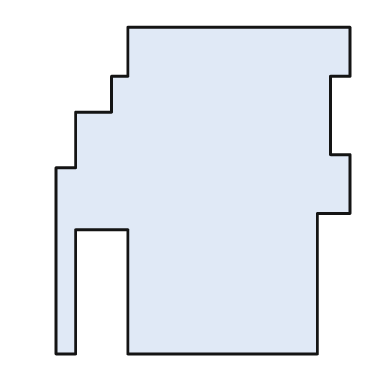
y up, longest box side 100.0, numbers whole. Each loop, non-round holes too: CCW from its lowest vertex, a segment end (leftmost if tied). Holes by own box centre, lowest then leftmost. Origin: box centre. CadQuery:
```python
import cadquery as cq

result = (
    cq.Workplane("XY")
    .moveTo(-45.0, -50.0)
    .lineTo(-39.0, -50.0)
    .lineTo(-39.0, -12.0)
    .lineTo(-23.0, -12.0)
    .lineTo(-23.0, -50.0)
    .lineTo(35.0, -50.0)
    .lineTo(35.0, -7.0)
    .lineTo(45.0, -7.0)
    .lineTo(45.0, 11.0)
    .lineTo(39.0, 11.0)
    .lineTo(39.0, 35.0)
    .lineTo(45.0, 35.0)
    .lineTo(45.0, 50.0)
    .lineTo(-23.0, 50.0)
    .lineTo(-23.0, 35.0)
    .lineTo(-28.0, 35.0)
    .lineTo(-28.0, 24.0)
    .lineTo(-39.0, 24.0)
    .lineTo(-39.0, 7.0)
    .lineTo(-45.0, 7.0)
    .close()
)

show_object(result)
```